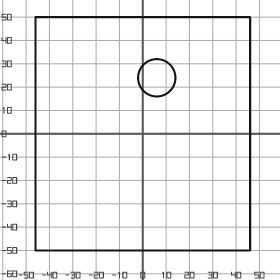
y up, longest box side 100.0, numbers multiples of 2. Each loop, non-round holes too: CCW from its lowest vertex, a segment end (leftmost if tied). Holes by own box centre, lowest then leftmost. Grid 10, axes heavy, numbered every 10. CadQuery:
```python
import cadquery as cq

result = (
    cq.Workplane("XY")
    .moveTo(-46.0, -50.0)
    .lineTo(46.0, -50.0)
    .lineTo(46.0, 50.0)
    .lineTo(-46.0, 50.0)
    .close()
    .moveTo(6.0, 24.0)
    .circle(8.0)
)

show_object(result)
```